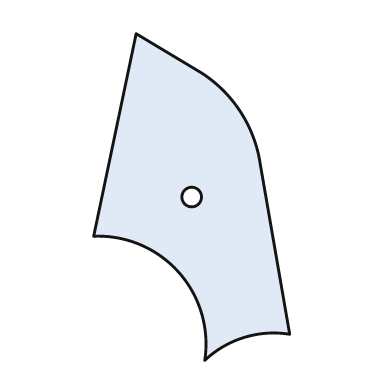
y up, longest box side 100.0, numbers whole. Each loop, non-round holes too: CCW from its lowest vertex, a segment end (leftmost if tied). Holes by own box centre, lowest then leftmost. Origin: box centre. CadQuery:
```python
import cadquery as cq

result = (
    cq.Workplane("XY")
    .moveTo(4.0, -50.0)
    .threePointArc((16.0, -43.0), (30.0, -42.0))
    .lineTo(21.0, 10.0)
    .threePointArc((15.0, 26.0), (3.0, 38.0))
    .lineTo(-17.0, 50.0)
    .lineTo(-30.0, -12.0)
    .threePointArc((-4.0, -23.0), (4.0, -50.0))
    .close()
    .moveTo(0.0, 0.0)
    .circle(3.0)
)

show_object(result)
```